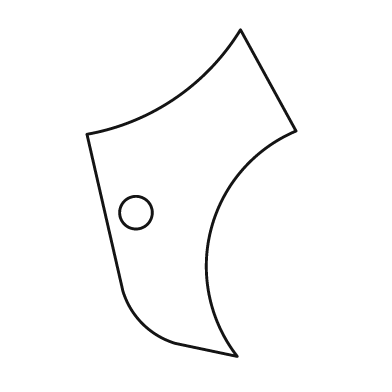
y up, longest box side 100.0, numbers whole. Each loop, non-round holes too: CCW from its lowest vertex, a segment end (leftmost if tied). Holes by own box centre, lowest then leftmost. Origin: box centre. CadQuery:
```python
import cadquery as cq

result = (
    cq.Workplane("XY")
    .moveTo(14.0, -50.0)
    .threePointArc((6.0, -11.0), (32.0, 19.0))
    .lineTo(15.0, 50.0)
    .threePointArc((-5.0, 29.0), (-32.0, 18.0))
    .lineTo(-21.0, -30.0)
    .threePointArc((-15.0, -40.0), (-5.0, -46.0))
    .close()
    .moveTo(-17.0, -6.0)
    .circle(5.0)
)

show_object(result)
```